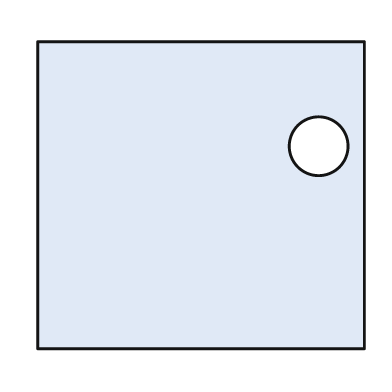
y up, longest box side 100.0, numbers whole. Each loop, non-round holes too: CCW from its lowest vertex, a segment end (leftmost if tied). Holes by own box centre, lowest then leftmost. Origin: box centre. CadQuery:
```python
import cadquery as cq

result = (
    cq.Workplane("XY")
    .moveTo(-50.0, -47.0)
    .lineTo(50.0, -47.0)
    .lineTo(50.0, 47.0)
    .lineTo(-50.0, 47.0)
    .close()
    .moveTo(36.0, 15.0)
    .circle(9.0)
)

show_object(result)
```